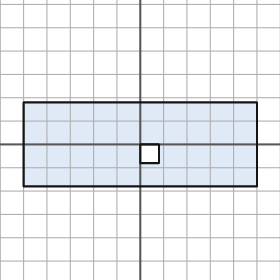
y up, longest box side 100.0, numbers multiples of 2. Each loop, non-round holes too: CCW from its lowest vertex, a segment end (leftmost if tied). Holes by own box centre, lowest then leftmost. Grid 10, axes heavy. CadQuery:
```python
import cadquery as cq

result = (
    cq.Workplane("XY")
    .moveTo(-50.0, -18.0)
    .lineTo(50.0, -18.0)
    .lineTo(50.0, 18.0)
    .lineTo(-50.0, 18.0)
    .close()
    .moveTo(0.0, -8.0)
    .lineTo(8.0, -8.0)
    .lineTo(8.0, 0.0)
    .lineTo(0.0, 0.0)
    .close()
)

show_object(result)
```